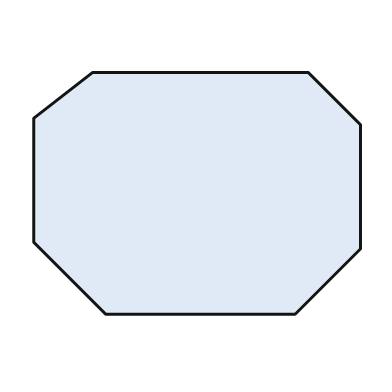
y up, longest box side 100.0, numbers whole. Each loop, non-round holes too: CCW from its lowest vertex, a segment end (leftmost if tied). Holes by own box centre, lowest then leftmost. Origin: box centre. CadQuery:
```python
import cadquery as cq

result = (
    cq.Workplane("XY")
    .moveTo(-28.0, -37.0)
    .lineTo(30.0, -37.0)
    .lineTo(50.0, -17.0)
    .lineTo(50.0, 21.0)
    .lineTo(34.0, 37.0)
    .lineTo(-32.0, 37.0)
    .lineTo(-50.0, 23.0)
    .lineTo(-50.0, -15.0)
    .close()
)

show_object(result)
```